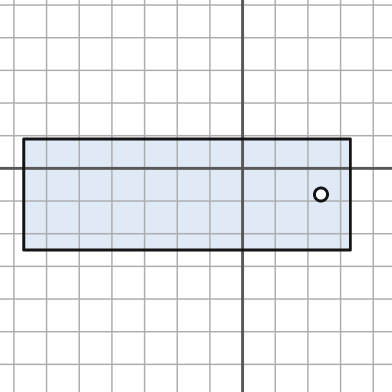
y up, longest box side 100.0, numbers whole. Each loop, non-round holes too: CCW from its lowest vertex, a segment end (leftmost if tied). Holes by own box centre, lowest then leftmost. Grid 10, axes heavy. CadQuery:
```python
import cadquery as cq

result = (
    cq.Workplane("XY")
    .moveTo(-67.0, -25.0)
    .lineTo(33.0, -25.0)
    .lineTo(33.0, 9.0)
    .lineTo(-67.0, 9.0)
    .close()
    .moveTo(24.0, -8.0)
    .circle(2.0)
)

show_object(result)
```